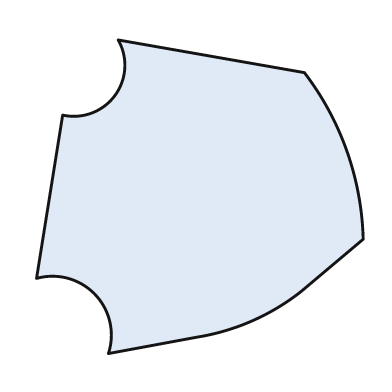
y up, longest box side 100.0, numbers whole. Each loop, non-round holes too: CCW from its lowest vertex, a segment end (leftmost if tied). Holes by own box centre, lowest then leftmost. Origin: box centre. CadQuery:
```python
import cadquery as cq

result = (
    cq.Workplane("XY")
    .moveTo(-28.0, -48.0)
    .lineTo(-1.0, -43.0)
    .threePointArc((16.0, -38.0), (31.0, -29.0))
    .lineTo(50.0, -13.0)
    .threePointArc((45.0, 14.0), (32.0, 38.0))
    .lineTo(-25.0, 48.0)
    .threePointArc((-26.0, 31.0), (-42.0, 25.0))
    .lineTo(-50.0, -25.0)
    .threePointArc((-32.0, -30.0), (-28.0, -48.0))
    .close()
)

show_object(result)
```